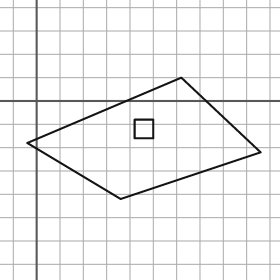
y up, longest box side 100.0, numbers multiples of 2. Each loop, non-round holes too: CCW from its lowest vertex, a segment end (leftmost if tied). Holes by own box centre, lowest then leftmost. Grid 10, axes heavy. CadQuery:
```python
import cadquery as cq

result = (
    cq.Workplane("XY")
    .moveTo(36.0, -42.0)
    .lineTo(96.0, -22.0)
    .lineTo(62.0, 10.0)
    .lineTo(-4.0, -18.0)
    .close()
    .moveTo(42.0, -16.0)
    .lineTo(50.0, -16.0)
    .lineTo(50.0, -8.0)
    .lineTo(42.0, -8.0)
    .close()
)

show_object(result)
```